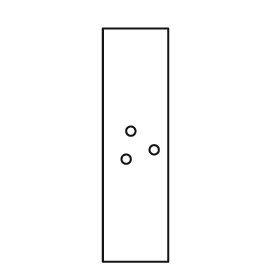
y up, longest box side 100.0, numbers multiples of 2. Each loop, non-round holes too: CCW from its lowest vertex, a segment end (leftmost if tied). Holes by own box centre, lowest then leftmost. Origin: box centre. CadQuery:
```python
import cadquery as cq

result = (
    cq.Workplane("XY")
    .moveTo(-14.0, -50.0)
    .lineTo(14.0, -50.0)
    .lineTo(14.0, 50.0)
    .lineTo(-14.0, 50.0)
    .close()
    .moveTo(-4.0, -6.0)
    .circle(2.0)
    .moveTo(8.0, -2.0)
    .circle(2.0)
    .moveTo(-2.0, 6.0)
    .circle(2.0)
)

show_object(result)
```